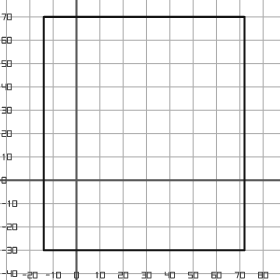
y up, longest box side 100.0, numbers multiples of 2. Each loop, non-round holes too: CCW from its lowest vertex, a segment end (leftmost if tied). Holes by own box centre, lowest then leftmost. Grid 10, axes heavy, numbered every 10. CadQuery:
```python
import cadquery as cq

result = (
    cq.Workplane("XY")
    .moveTo(-14.0, -30.0)
    .lineTo(72.0, -30.0)
    .lineTo(72.0, 70.0)
    .lineTo(-14.0, 70.0)
    .close()
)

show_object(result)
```